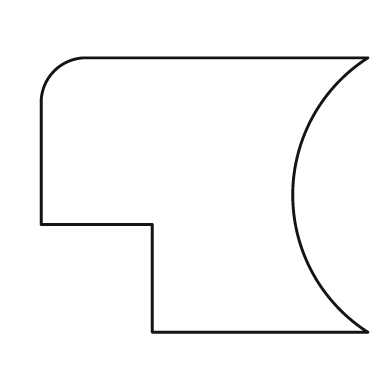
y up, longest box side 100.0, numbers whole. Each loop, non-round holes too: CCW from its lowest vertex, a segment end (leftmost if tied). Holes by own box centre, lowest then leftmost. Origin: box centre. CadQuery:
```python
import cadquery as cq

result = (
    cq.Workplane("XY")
    .moveTo(-16.0, -42.0)
    .lineTo(50.0, -42.0)
    .threePointArc((27.0, 0.0), (50.0, 42.0))
    .lineTo(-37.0, 42.0)
    .threePointArc((-46.0, 38.0), (-50.0, 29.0))
    .lineTo(-50.0, -9.0)
    .lineTo(-16.0, -9.0)
    .close()
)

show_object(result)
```